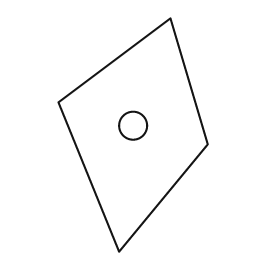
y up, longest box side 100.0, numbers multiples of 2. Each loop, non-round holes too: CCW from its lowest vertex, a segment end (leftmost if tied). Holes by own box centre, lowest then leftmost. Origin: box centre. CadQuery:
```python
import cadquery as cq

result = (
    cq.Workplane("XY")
    .moveTo(-6.0, -50.0)
    .lineTo(32.0, -4.0)
    .lineTo(16.0, 50.0)
    .lineTo(-32.0, 14.0)
    .close()
    .moveTo(0.0, 4.0)
    .circle(6.0)
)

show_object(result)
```